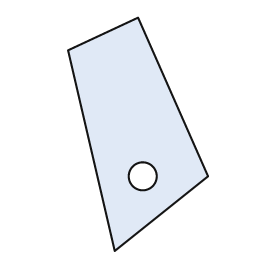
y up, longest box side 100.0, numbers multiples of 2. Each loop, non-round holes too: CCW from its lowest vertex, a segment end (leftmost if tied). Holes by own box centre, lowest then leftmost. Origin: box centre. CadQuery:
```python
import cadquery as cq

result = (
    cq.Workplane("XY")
    .moveTo(-10.0, -50.0)
    .lineTo(30.0, -18.0)
    .lineTo(0.0, 50.0)
    .lineTo(-30.0, 36.0)
    .close()
    .moveTo(2.0, -18.0)
    .circle(6.0)
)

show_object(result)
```